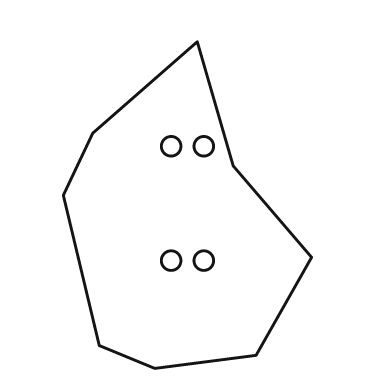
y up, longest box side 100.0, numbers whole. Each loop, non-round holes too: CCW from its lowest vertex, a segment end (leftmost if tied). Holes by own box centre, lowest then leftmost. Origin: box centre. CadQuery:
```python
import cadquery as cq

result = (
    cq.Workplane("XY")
    .moveTo(-10.0, -50.0)
    .lineTo(21.0, -46.0)
    .lineTo(38.0, -16.0)
    .lineTo(14.0, 12.0)
    .lineTo(3.0, 50.0)
    .lineTo(-29.0, 22.0)
    .lineTo(-38.0, 3.0)
    .lineTo(-27.0, -43.0)
    .close()
    .moveTo(-5.0, -17.0)
    .circle(3.0)
    .moveTo(5.0, -17.0)
    .circle(3.0)
    .moveTo(-5.0, 18.0)
    .circle(3.0)
    .moveTo(5.0, 18.0)
    .circle(3.0)
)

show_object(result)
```